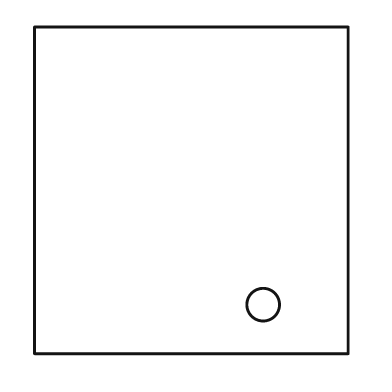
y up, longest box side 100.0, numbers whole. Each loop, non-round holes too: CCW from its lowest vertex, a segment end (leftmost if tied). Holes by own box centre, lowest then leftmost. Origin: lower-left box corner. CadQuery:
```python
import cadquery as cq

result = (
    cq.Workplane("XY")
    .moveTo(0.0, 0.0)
    .lineTo(96.0, 0.0)
    .lineTo(96.0, 100.0)
    .lineTo(0.0, 100.0)
    .close()
    .moveTo(70.0, 15.0)
    .circle(5.0)
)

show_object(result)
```